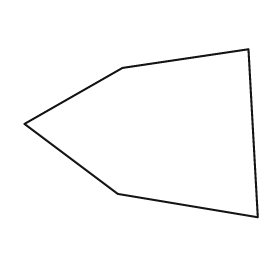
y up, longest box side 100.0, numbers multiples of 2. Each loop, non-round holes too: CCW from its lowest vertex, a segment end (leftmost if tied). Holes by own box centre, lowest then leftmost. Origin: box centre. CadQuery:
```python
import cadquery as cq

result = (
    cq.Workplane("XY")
    .moveTo(50.0, -36.0)
    .lineTo(46.0, 36.0)
    .lineTo(-8.0, 28.0)
    .lineTo(-50.0, 4.0)
    .lineTo(-10.0, -26.0)
    .close()
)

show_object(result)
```